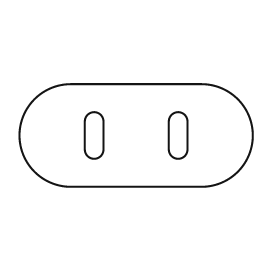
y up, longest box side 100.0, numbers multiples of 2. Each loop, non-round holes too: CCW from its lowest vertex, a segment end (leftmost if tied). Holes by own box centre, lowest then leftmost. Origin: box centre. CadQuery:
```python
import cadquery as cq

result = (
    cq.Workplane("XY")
    .moveTo(-28.0, -22.0)
    .lineTo(28.0, -22.0)
    .threePointArc((50.0, 0.0), (28.0, 22.0))
    .lineTo(-28.0, 22.0)
    .threePointArc((-50.0, 0.0), (-28.0, -22.0))
    .close()
    .moveTo(-22.0, -6.0)
    .threePointArc((-18.0, -10.0), (-14.0, -6.0))
    .lineTo(-14.0, 6.0)
    .threePointArc((-18.0, 10.0), (-22.0, 6.0))
    .close()
    .moveTo(14.0, -6.0)
    .threePointArc((18.0, -10.0), (22.0, -6.0))
    .lineTo(22.0, 6.0)
    .threePointArc((18.0, 10.0), (14.0, 6.0))
    .close()
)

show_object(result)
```